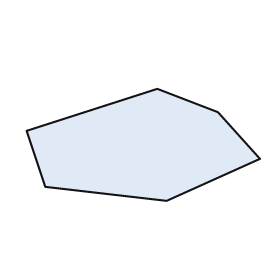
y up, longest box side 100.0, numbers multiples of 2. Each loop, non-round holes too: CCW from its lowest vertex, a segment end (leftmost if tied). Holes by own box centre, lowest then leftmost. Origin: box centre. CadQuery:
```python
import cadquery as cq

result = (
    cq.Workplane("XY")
    .moveTo(10.0, -24.0)
    .lineTo(50.0, -6.0)
    .lineTo(32.0, 14.0)
    .lineTo(6.0, 24.0)
    .lineTo(-50.0, 6.0)
    .lineTo(-42.0, -18.0)
    .close()
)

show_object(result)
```